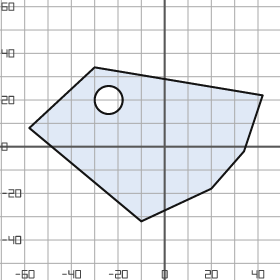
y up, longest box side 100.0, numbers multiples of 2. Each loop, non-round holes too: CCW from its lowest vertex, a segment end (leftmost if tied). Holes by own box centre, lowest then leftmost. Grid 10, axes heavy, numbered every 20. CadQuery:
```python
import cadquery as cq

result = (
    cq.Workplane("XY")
    .moveTo(-10.0, -32.0)
    .lineTo(20.0, -18.0)
    .lineTo(34.0, -2.0)
    .lineTo(42.0, 22.0)
    .lineTo(-30.0, 34.0)
    .lineTo(-58.0, 8.0)
    .close()
    .moveTo(-24.0, 20.0)
    .circle(6.0)
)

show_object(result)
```